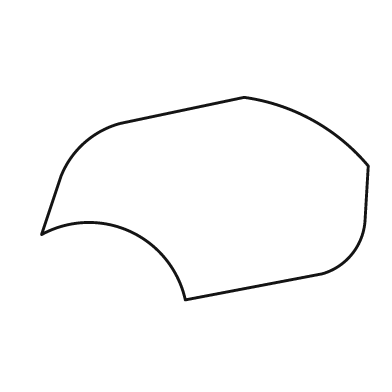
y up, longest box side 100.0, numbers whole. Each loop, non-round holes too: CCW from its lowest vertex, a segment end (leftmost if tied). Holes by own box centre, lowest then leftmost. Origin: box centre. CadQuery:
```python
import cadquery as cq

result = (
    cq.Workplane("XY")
    .moveTo(-6.0, -31.0)
    .lineTo(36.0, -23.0)
    .threePointArc((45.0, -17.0), (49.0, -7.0))
    .lineTo(50.0, 10.0)
    .threePointArc((33.0, 24.0), (12.0, 31.0))
    .lineTo(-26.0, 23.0)
    .threePointArc((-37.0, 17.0), (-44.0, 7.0))
    .lineTo(-50.0, -11.0)
    .threePointArc((-23.0, -10.0), (-6.0, -31.0))
    .close()
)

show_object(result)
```